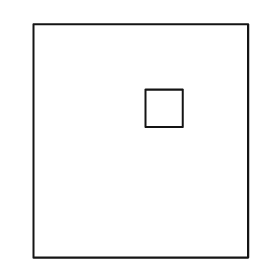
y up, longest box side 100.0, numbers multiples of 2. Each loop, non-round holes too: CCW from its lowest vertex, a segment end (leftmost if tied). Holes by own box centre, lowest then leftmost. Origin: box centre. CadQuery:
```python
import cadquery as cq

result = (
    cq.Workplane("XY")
    .moveTo(-46.0, -50.0)
    .lineTo(46.0, -50.0)
    .lineTo(46.0, 50.0)
    .lineTo(-46.0, 50.0)
    .close()
    .moveTo(2.0, 6.0)
    .lineTo(18.0, 6.0)
    .lineTo(18.0, 22.0)
    .lineTo(2.0, 22.0)
    .close()
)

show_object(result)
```